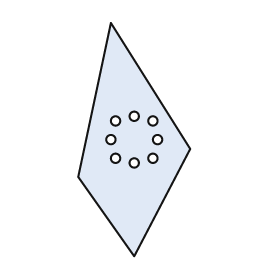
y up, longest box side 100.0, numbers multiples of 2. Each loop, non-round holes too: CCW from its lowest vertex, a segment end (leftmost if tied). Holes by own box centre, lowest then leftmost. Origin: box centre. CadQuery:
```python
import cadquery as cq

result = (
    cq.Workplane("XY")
    .moveTo(0.0, -50.0)
    .lineTo(24.0, -4.0)
    .lineTo(-10.0, 50.0)
    .lineTo(-24.0, -16.0)
    .close()
    .moveTo(0.0, -10.0)
    .circle(2.0)
    .moveTo(-8.0, -8.0)
    .circle(2.0)
    .moveTo(8.0, -8.0)
    .circle(2.0)
    .moveTo(-10.0, 0.0)
    .circle(2.0)
    .moveTo(10.0, 0.0)
    .circle(2.0)
    .moveTo(-8.0, 8.0)
    .circle(2.0)
    .moveTo(8.0, 8.0)
    .circle(2.0)
    .moveTo(0.0, 10.0)
    .circle(2.0)
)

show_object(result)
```